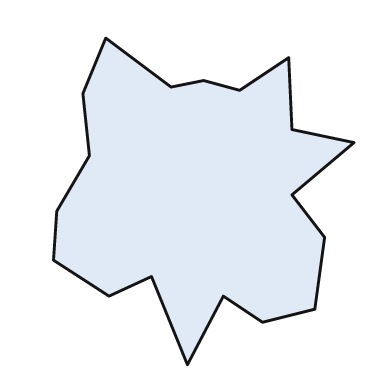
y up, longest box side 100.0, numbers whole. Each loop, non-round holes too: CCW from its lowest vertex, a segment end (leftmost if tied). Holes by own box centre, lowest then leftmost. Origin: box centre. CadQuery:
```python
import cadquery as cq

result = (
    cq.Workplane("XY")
    .moveTo(-5.0, -50.0)
    .lineTo(6.0, -29.0)
    .lineTo(18.0, -37.0)
    .lineTo(34.0, -33.0)
    .lineTo(37.0, -11.0)
    .lineTo(27.0, 2.0)
    .lineTo(46.0, 18.0)
    .lineTo(27.0, 22.0)
    .lineTo(26.0, 44.0)
    .lineTo(11.0, 34.0)
    .lineTo(0.0, 37.0)
    .lineTo(-10.0, 35.0)
    .lineTo(-30.0, 50.0)
    .lineTo(-37.0, 33.0)
    .lineTo(-35.0, 14.0)
    .lineTo(-45.0, -3.0)
    .lineTo(-46.0, -18.0)
    .lineTo(-29.0, -29.0)
    .lineTo(-16.0, -23.0)
    .close()
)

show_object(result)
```